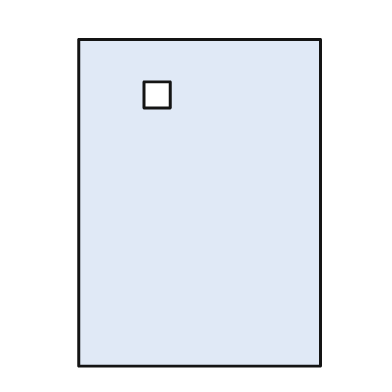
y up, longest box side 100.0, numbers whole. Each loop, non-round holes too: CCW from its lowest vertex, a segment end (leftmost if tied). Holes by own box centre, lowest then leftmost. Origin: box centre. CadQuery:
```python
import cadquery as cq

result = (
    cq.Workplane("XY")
    .moveTo(-37.0, -50.0)
    .lineTo(37.0, -50.0)
    .lineTo(37.0, 50.0)
    .lineTo(-37.0, 50.0)
    .close()
    .moveTo(-17.0, 29.0)
    .lineTo(-9.0, 29.0)
    .lineTo(-9.0, 37.0)
    .lineTo(-17.0, 37.0)
    .close()
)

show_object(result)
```